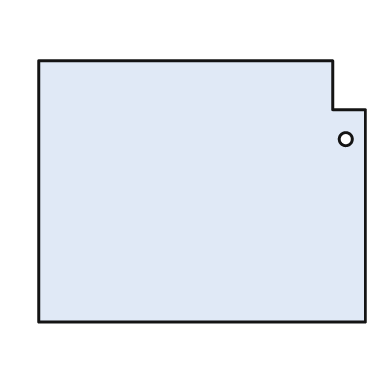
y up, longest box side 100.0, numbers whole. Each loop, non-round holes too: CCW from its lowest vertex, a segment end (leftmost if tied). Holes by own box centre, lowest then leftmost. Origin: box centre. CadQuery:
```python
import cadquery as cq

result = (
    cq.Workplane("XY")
    .moveTo(-50.0, -40.0)
    .lineTo(50.0, -40.0)
    .lineTo(50.0, 25.0)
    .lineTo(40.0, 25.0)
    .lineTo(40.0, 40.0)
    .lineTo(-50.0, 40.0)
    .close()
    .moveTo(44.0, 16.0)
    .circle(2.0)
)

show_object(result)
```